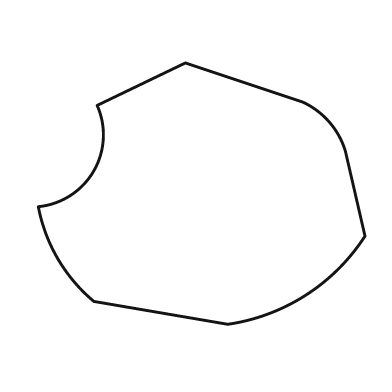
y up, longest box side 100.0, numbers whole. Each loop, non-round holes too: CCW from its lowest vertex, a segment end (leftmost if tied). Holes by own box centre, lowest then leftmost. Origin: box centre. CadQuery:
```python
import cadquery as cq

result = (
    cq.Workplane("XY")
    .moveTo(8.0, -40.0)
    .threePointArc((32.0, -31.0), (50.0, -13.0))
    .lineTo(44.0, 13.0)
    .threePointArc((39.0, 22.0), (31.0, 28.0))
    .lineTo(-5.0, 40.0)
    .lineTo(-32.0, 27.0)
    .threePointArc((-33.0, 7.0), (-50.0, -4.0))
    .threePointArc((-44.0, -20.0), (-33.0, -33.0))
    .close()
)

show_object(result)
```